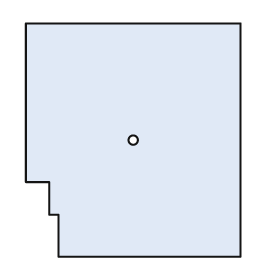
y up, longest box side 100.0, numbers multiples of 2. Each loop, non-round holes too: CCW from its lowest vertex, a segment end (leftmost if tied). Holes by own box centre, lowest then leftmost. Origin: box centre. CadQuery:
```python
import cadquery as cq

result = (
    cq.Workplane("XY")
    .moveTo(-32.0, -50.0)
    .lineTo(46.0, -50.0)
    .lineTo(46.0, 50.0)
    .lineTo(-46.0, 50.0)
    .lineTo(-46.0, -18.0)
    .lineTo(-36.0, -18.0)
    .lineTo(-36.0, -32.0)
    .lineTo(-32.0, -32.0)
    .close()
    .moveTo(0.0, 0.0)
    .circle(2.0)
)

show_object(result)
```